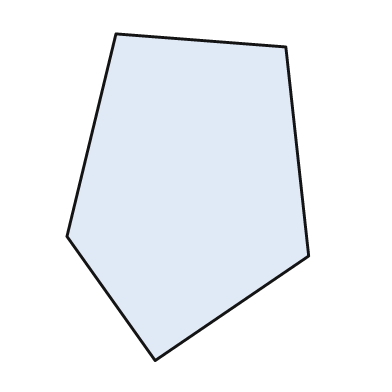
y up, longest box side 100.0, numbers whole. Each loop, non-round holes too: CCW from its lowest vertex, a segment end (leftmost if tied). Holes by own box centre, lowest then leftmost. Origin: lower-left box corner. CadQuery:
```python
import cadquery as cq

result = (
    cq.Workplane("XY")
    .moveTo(27.0, 0.0)
    .lineTo(74.0, 32.0)
    .lineTo(67.0, 96.0)
    .lineTo(15.0, 100.0)
    .lineTo(0.0, 38.0)
    .close()
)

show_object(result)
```